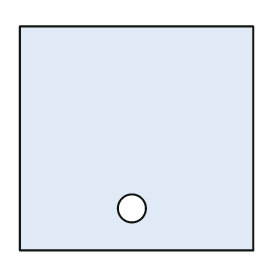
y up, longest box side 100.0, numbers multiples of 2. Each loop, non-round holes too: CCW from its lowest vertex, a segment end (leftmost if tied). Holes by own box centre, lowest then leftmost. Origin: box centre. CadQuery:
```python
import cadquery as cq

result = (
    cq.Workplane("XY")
    .moveTo(-50.0, -48.0)
    .lineTo(50.0, -48.0)
    .lineTo(50.0, 48.0)
    .lineTo(-50.0, 48.0)
    .close()
    .moveTo(-2.0, -30.0)
    .circle(6.0)
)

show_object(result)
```